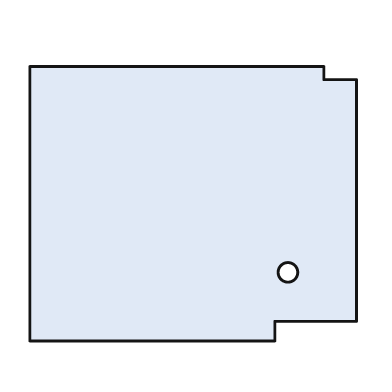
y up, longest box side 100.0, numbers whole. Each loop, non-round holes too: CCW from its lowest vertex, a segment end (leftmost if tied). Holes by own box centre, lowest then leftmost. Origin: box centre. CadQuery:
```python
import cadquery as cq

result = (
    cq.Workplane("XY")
    .moveTo(-50.0, -42.0)
    .lineTo(25.0, -42.0)
    .lineTo(25.0, -36.0)
    .lineTo(50.0, -36.0)
    .lineTo(50.0, 38.0)
    .lineTo(40.0, 38.0)
    .lineTo(40.0, 42.0)
    .lineTo(-50.0, 42.0)
    .close()
    .moveTo(29.0, -21.0)
    .circle(3.0)
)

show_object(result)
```